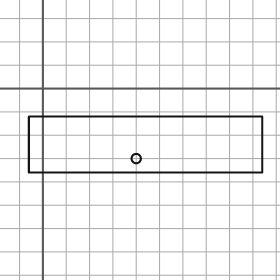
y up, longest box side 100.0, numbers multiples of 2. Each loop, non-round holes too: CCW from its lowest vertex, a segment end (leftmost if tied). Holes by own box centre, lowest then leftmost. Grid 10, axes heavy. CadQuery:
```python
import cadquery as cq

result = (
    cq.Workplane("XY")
    .moveTo(-6.0, -36.0)
    .lineTo(94.0, -36.0)
    .lineTo(94.0, -12.0)
    .lineTo(-6.0, -12.0)
    .close()
    .moveTo(40.0, -30.0)
    .circle(2.0)
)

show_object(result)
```